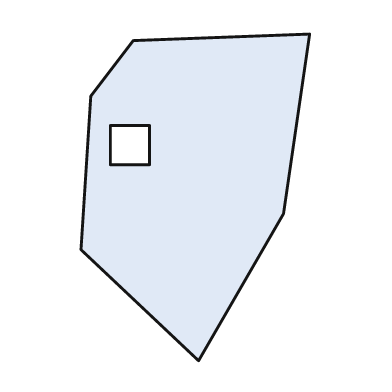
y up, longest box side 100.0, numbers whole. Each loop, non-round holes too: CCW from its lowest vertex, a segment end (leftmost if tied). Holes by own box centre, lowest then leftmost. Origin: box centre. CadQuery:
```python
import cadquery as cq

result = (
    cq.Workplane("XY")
    .moveTo(1.0, -50.0)
    .lineTo(27.0, -5.0)
    .lineTo(35.0, 50.0)
    .lineTo(-19.0, 48.0)
    .lineTo(-32.0, 31.0)
    .lineTo(-35.0, -16.0)
    .close()
    .moveTo(-26.0, 10.0)
    .lineTo(-14.0, 10.0)
    .lineTo(-14.0, 22.0)
    .lineTo(-26.0, 22.0)
    .close()
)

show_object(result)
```